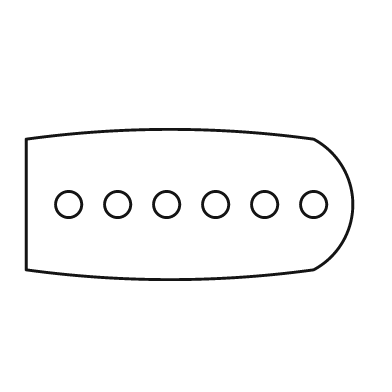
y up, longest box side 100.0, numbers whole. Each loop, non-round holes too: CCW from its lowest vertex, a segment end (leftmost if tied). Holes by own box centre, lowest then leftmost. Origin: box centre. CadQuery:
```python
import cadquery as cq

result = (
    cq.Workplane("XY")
    .moveTo(-50.0, -20.0)
    .threePointArc((-6.0, -23.0), (38.0, -20.0))
    .threePointArc((50.0, 0.0), (38.0, 20.0))
    .threePointArc((-6.0, 23.0), (-50.0, 20.0))
    .close()
    .moveTo(-37.0, 0.0)
    .circle(4.0)
    .moveTo(-22.0, 0.0)
    .circle(4.0)
    .moveTo(-7.0, 0.0)
    .circle(4.0)
    .moveTo(8.0, 0.0)
    .circle(4.0)
    .moveTo(23.0, 0.0)
    .circle(4.0)
    .moveTo(38.0, 0.0)
    .circle(4.0)
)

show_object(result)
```